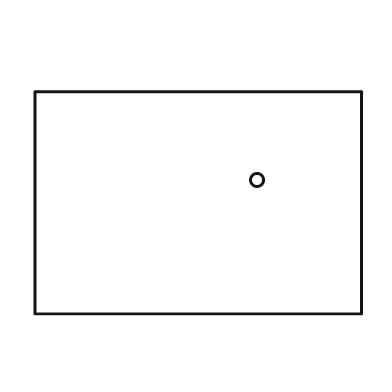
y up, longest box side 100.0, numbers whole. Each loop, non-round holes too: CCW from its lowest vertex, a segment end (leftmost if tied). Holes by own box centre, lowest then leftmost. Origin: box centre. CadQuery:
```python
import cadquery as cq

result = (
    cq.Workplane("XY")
    .moveTo(-50.0, -34.0)
    .lineTo(50.0, -34.0)
    .lineTo(50.0, 34.0)
    .lineTo(-50.0, 34.0)
    .close()
    .moveTo(18.0, 7.0)
    .circle(2.0)
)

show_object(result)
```